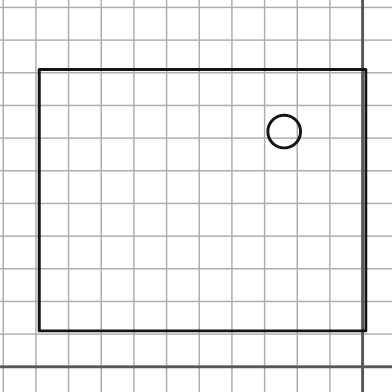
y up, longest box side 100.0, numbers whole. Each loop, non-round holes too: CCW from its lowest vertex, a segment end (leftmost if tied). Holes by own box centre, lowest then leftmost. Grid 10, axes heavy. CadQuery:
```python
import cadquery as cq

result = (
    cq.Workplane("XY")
    .moveTo(-99.0, 11.0)
    .lineTo(1.0, 11.0)
    .lineTo(1.0, 91.0)
    .lineTo(-99.0, 91.0)
    .close()
    .moveTo(-24.0, 72.0)
    .circle(5.0)
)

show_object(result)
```